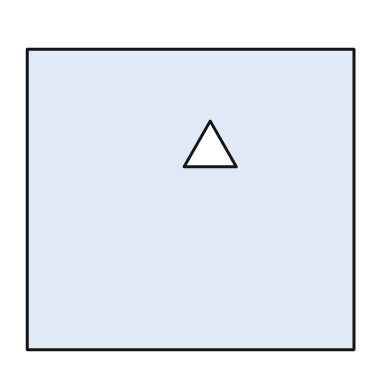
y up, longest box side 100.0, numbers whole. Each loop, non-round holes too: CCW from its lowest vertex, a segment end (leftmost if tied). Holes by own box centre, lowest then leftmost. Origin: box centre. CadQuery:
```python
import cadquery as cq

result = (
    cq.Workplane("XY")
    .moveTo(-50.0, -46.0)
    .lineTo(50.0, -46.0)
    .lineTo(50.0, 46.0)
    .lineTo(-50.0, 46.0)
    .close()
    .moveTo(-2.0, 10.0)
    .lineTo(14.0, 10.0)
    .lineTo(6.0, 24.0)
    .close()
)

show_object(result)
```